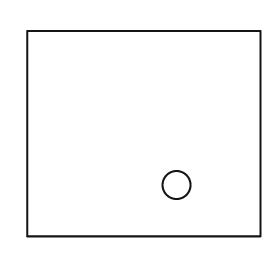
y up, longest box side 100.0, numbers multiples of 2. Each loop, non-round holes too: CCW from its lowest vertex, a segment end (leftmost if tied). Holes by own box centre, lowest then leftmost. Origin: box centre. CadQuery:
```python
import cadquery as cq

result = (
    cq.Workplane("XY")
    .moveTo(-50.0, -44.0)
    .lineTo(50.0, -44.0)
    .lineTo(50.0, 44.0)
    .lineTo(-50.0, 44.0)
    .close()
    .moveTo(14.0, -22.0)
    .circle(6.0)
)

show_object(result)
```